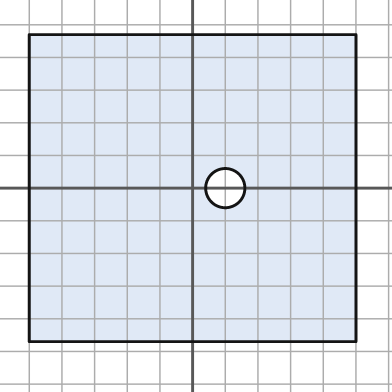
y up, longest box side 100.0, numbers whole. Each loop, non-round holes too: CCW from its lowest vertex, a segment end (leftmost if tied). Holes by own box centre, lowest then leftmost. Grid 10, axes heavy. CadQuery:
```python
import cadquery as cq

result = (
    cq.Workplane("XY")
    .moveTo(-50.0, -47.0)
    .lineTo(50.0, -47.0)
    .lineTo(50.0, 47.0)
    .lineTo(-50.0, 47.0)
    .close()
    .moveTo(10.0, 0.0)
    .circle(6.0)
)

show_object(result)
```